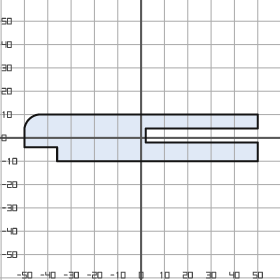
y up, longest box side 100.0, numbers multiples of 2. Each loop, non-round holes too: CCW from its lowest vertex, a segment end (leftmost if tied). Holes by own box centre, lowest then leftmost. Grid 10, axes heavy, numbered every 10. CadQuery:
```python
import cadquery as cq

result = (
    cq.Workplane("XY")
    .moveTo(-36.0, -10.0)
    .lineTo(50.0, -10.0)
    .lineTo(50.0, -2.0)
    .lineTo(2.0, -2.0)
    .lineTo(2.0, 4.0)
    .lineTo(50.0, 4.0)
    .lineTo(50.0, 10.0)
    .lineTo(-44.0, 10.0)
    .threePointArc((-48.0, 8.0), (-50.0, 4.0))
    .lineTo(-50.0, -4.0)
    .lineTo(-36.0, -4.0)
    .close()
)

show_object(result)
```